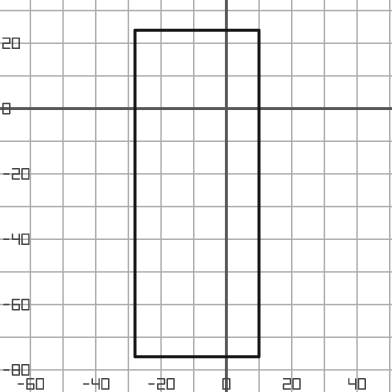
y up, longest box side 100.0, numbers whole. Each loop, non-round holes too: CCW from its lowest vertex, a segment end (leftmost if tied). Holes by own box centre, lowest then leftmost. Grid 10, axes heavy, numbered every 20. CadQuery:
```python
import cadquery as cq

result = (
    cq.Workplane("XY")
    .moveTo(-28.0, -76.0)
    .lineTo(10.0, -76.0)
    .lineTo(10.0, 24.0)
    .lineTo(-28.0, 24.0)
    .close()
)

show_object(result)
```